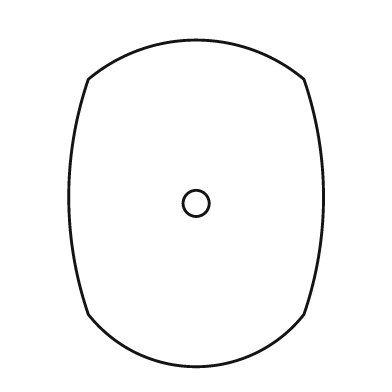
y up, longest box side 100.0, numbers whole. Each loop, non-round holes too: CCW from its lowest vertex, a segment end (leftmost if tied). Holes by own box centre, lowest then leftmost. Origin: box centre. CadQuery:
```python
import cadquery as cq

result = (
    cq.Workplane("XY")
    .moveTo(-33.0, -34.0)
    .threePointArc((0.0, -50.0), (33.0, -34.0))
    .threePointArc((39.0, 2.0), (33.0, 38.0))
    .threePointArc((0.0, 50.0), (-33.0, 38.0))
    .threePointArc((-39.0, 2.0), (-33.0, -34.0))
    .close()
    .moveTo(0.0, 0.0)
    .circle(4.0)
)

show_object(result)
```